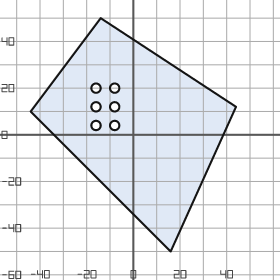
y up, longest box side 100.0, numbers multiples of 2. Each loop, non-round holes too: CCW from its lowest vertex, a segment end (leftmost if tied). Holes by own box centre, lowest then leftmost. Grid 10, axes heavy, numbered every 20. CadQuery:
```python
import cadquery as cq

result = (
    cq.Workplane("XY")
    .moveTo(16.0, -50.0)
    .lineTo(44.0, 12.0)
    .lineTo(-14.0, 50.0)
    .lineTo(-44.0, 10.0)
    .close()
    .moveTo(-16.0, 4.0)
    .circle(2.0)
    .moveTo(-8.0, 4.0)
    .circle(2.0)
    .moveTo(-16.0, 12.0)
    .circle(2.0)
    .moveTo(-8.0, 12.0)
    .circle(2.0)
    .moveTo(-16.0, 20.0)
    .circle(2.0)
    .moveTo(-8.0, 20.0)
    .circle(2.0)
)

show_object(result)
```